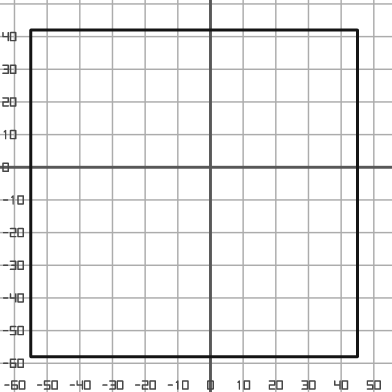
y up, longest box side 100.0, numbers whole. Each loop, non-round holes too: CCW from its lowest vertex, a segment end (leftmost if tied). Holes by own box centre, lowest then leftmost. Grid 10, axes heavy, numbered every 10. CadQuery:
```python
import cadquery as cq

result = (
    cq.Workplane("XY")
    .moveTo(-55.0, -58.0)
    .lineTo(45.0, -58.0)
    .lineTo(45.0, 42.0)
    .lineTo(-55.0, 42.0)
    .close()
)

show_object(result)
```